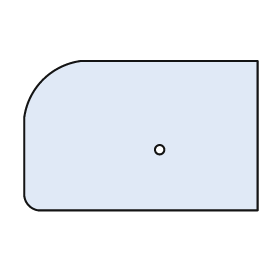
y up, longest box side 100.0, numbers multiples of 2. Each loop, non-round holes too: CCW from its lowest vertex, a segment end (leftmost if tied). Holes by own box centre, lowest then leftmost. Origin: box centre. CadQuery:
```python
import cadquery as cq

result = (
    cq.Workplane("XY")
    .moveTo(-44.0, -32.0)
    .lineTo(50.0, -32.0)
    .lineTo(50.0, 32.0)
    .lineTo(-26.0, 32.0)
    .threePointArc((-42.0, 24.0), (-50.0, 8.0))
    .lineTo(-50.0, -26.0)
    .threePointArc((-48.0, -30.0), (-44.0, -32.0))
    .close()
    .moveTo(8.0, -6.0)
    .circle(2.0)
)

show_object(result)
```